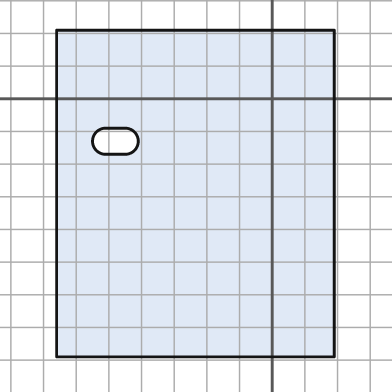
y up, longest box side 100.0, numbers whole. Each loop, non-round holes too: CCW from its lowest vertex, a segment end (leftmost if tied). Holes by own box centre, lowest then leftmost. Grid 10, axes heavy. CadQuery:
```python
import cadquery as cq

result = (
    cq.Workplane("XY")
    .moveTo(-66.0, -79.0)
    .lineTo(19.0, -79.0)
    .lineTo(19.0, 21.0)
    .lineTo(-66.0, 21.0)
    .close()
    .moveTo(-51.0, -17.0)
    .lineTo(-45.0, -17.0)
    .threePointArc((-41.0, -13.0), (-45.0, -9.0))
    .lineTo(-51.0, -9.0)
    .threePointArc((-55.0, -13.0), (-51.0, -17.0))
    .close()
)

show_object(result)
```